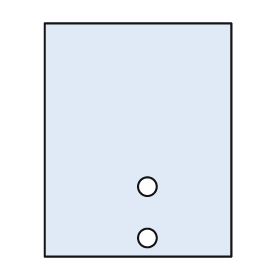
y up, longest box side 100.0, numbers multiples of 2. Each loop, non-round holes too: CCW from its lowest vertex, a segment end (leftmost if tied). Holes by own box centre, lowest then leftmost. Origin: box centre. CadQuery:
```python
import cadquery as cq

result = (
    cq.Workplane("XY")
    .moveTo(-40.0, -50.0)
    .lineTo(40.0, -50.0)
    .lineTo(40.0, 50.0)
    .lineTo(-40.0, 50.0)
    .close()
    .moveTo(4.0, -42.0)
    .circle(4.0)
    .moveTo(4.0, -20.0)
    .circle(4.0)
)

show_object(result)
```